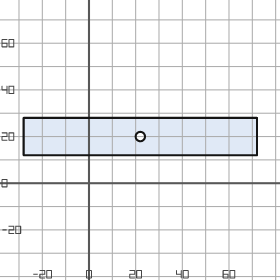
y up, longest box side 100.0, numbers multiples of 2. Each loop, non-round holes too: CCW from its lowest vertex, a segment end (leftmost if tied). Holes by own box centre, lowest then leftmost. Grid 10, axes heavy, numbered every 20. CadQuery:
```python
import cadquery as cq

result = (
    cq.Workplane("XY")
    .moveTo(-28.0, 12.0)
    .lineTo(72.0, 12.0)
    .lineTo(72.0, 28.0)
    .lineTo(-28.0, 28.0)
    .close()
    .moveTo(22.0, 20.0)
    .circle(2.0)
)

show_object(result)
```